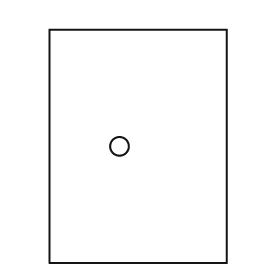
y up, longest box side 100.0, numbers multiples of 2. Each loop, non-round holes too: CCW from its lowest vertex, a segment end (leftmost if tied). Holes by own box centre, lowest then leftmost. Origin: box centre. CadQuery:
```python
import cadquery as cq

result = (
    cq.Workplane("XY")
    .moveTo(-38.0, -50.0)
    .lineTo(38.0, -50.0)
    .lineTo(38.0, 50.0)
    .lineTo(-38.0, 50.0)
    .close()
    .moveTo(-8.0, 0.0)
    .circle(4.0)
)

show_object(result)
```